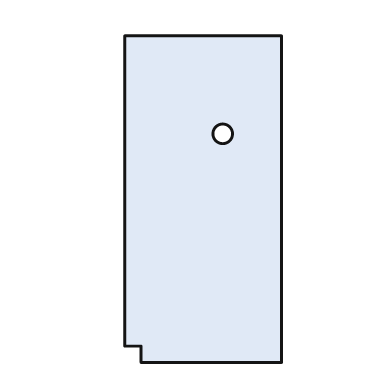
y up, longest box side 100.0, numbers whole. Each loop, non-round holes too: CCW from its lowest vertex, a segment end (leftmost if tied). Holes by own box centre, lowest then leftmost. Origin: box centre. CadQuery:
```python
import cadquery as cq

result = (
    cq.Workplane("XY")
    .moveTo(-19.0, -50.0)
    .lineTo(24.0, -50.0)
    .lineTo(24.0, 50.0)
    .lineTo(-24.0, 50.0)
    .lineTo(-24.0, -45.0)
    .lineTo(-19.0, -45.0)
    .close()
    .moveTo(6.0, 20.0)
    .circle(3.0)
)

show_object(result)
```